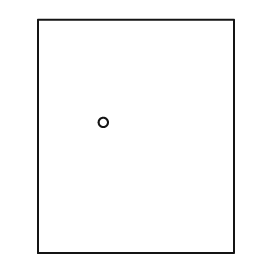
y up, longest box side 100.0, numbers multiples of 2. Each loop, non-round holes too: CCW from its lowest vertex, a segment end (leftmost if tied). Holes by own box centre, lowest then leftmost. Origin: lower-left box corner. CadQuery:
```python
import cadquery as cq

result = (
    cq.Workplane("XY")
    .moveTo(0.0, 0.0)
    .lineTo(84.0, 0.0)
    .lineTo(84.0, 100.0)
    .lineTo(0.0, 100.0)
    .close()
    .moveTo(28.0, 56.0)
    .circle(2.0)
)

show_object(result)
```